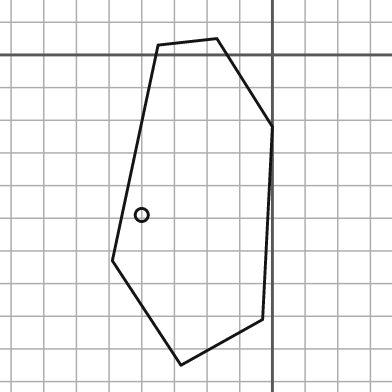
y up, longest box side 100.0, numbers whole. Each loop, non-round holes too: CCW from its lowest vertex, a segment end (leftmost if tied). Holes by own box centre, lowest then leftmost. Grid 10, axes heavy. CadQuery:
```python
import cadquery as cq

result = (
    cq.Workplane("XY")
    .moveTo(-28.0, -95.0)
    .lineTo(-3.0, -81.0)
    .lineTo(0.0, -22.0)
    .lineTo(-17.0, 5.0)
    .lineTo(-35.0, 3.0)
    .lineTo(-49.0, -63.0)
    .close()
    .moveTo(-40.0, -49.0)
    .circle(2.0)
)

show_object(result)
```